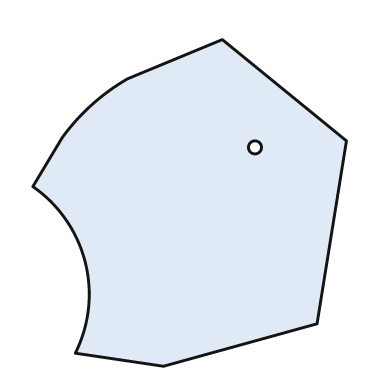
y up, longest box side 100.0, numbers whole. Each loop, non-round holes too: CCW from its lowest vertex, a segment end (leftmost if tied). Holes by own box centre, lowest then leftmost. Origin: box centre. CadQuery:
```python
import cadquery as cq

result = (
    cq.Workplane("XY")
    .moveTo(-8.0, -50.0)
    .lineTo(39.0, -37.0)
    .lineTo(48.0, 19.0)
    .lineTo(10.0, 50.0)
    .lineTo(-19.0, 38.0)
    .threePointArc((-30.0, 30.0), (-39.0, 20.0))
    .lineTo(-48.0, 5.0)
    .threePointArc((-32.0, -18.0), (-35.0, -46.0))
    .close()
    .moveTo(20.0, 17.0)
    .circle(2.0)
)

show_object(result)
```